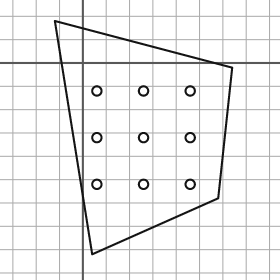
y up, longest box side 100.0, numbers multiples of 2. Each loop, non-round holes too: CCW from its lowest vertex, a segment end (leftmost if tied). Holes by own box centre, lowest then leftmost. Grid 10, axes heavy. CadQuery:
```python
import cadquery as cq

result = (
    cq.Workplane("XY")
    .moveTo(4.0, -82.0)
    .lineTo(58.0, -58.0)
    .lineTo(64.0, -2.0)
    .lineTo(-12.0, 18.0)
    .close()
    .moveTo(6.0, -52.0)
    .circle(2.0)
    .moveTo(26.0, -52.0)
    .circle(2.0)
    .moveTo(46.0, -52.0)
    .circle(2.0)
    .moveTo(6.0, -32.0)
    .circle(2.0)
    .moveTo(26.0, -32.0)
    .circle(2.0)
    .moveTo(46.0, -32.0)
    .circle(2.0)
    .moveTo(6.0, -12.0)
    .circle(2.0)
    .moveTo(26.0, -12.0)
    .circle(2.0)
    .moveTo(46.0, -12.0)
    .circle(2.0)
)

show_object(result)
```